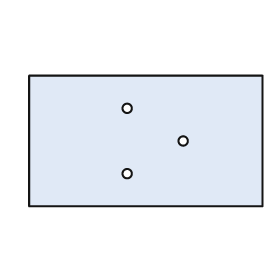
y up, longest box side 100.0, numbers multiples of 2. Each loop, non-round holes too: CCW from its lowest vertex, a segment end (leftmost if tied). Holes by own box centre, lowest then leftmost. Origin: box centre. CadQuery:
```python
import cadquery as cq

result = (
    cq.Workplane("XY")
    .moveTo(-50.0, -28.0)
    .lineTo(50.0, -28.0)
    .lineTo(50.0, 28.0)
    .lineTo(-50.0, 28.0)
    .close()
    .moveTo(-8.0, -14.0)
    .circle(2.0)
    .moveTo(16.0, 0.0)
    .circle(2.0)
    .moveTo(-8.0, 14.0)
    .circle(2.0)
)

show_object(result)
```